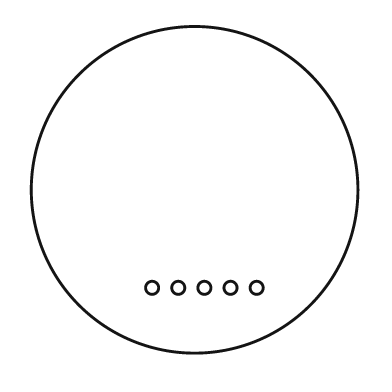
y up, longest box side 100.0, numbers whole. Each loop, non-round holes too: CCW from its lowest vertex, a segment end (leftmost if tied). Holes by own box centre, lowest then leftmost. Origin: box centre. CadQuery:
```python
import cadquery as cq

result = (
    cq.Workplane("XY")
    .moveTo(0.0, 0.0)
    .circle(50.0)
    .moveTo(-13.0, -30.0)
    .circle(2.0)
    .moveTo(-5.0, -30.0)
    .circle(2.0)
    .moveTo(3.0, -30.0)
    .circle(2.0)
    .moveTo(11.0, -30.0)
    .circle(2.0)
    .moveTo(19.0, -30.0)
    .circle(2.0)
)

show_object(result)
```